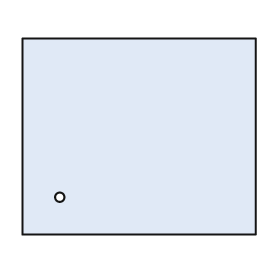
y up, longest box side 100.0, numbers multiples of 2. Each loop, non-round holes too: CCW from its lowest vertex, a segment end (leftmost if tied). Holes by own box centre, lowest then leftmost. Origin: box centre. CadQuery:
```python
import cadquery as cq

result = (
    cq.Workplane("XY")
    .moveTo(-50.0, -42.0)
    .lineTo(50.0, -42.0)
    .lineTo(50.0, 42.0)
    .lineTo(-50.0, 42.0)
    .close()
    .moveTo(-34.0, -26.0)
    .circle(2.0)
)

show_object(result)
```